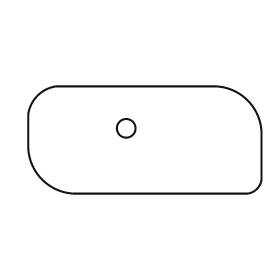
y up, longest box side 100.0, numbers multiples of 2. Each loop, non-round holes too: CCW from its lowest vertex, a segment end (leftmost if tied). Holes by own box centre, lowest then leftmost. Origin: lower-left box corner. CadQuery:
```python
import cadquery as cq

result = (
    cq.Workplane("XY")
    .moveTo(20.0, 0.0)
    .lineTo(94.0, 0.0)
    .threePointArc((98.0, 2.0), (100.0, 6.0))
    .lineTo(100.0, 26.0)
    .threePointArc((94.0, 40.0), (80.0, 46.0))
    .lineTo(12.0, 46.0)
    .threePointArc((4.0, 42.0), (0.0, 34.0))
    .lineTo(0.0, 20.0)
    .threePointArc((6.0, 6.0), (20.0, 0.0))
    .close()
    .moveTo(42.0, 28.0)
    .circle(4.0)
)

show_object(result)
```